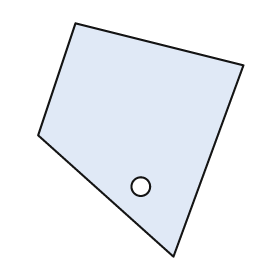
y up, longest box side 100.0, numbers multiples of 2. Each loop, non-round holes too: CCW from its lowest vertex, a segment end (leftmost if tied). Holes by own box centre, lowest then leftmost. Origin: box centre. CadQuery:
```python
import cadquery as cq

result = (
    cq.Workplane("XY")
    .moveTo(14.0, -50.0)
    .lineTo(44.0, 32.0)
    .lineTo(-28.0, 50.0)
    .lineTo(-44.0, 2.0)
    .close()
    .moveTo(0.0, -20.0)
    .circle(4.0)
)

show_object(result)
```